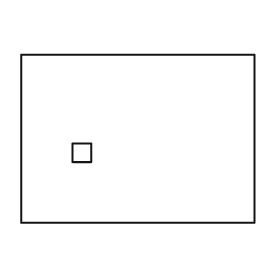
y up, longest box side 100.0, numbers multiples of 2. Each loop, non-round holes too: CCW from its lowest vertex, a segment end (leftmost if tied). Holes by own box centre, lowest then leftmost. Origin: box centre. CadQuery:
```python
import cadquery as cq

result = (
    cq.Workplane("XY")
    .moveTo(-50.0, -36.0)
    .lineTo(50.0, -36.0)
    .lineTo(50.0, 36.0)
    .lineTo(-50.0, 36.0)
    .close()
    .moveTo(-28.0, -10.0)
    .lineTo(-20.0, -10.0)
    .lineTo(-20.0, -2.0)
    .lineTo(-28.0, -2.0)
    .close()
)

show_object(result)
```